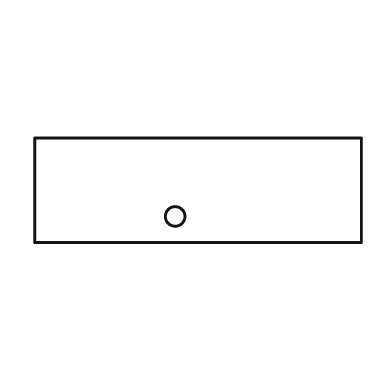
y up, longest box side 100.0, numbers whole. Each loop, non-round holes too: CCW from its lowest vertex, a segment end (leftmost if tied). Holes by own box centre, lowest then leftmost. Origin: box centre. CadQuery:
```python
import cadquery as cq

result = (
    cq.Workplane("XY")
    .moveTo(-50.0, -16.0)
    .lineTo(50.0, -16.0)
    .lineTo(50.0, 16.0)
    .lineTo(-50.0, 16.0)
    .close()
    .moveTo(-7.0, -8.0)
    .circle(3.0)
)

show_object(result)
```